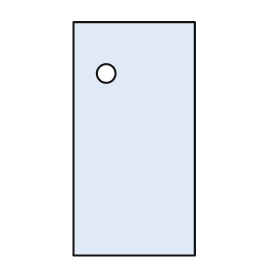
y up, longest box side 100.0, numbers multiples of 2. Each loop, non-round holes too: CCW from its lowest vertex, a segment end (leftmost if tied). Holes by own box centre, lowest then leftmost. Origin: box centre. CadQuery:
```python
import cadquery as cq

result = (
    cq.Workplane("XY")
    .moveTo(-26.0, -50.0)
    .lineTo(26.0, -50.0)
    .lineTo(26.0, 50.0)
    .lineTo(-26.0, 50.0)
    .close()
    .moveTo(-12.0, 28.0)
    .circle(4.0)
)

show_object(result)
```